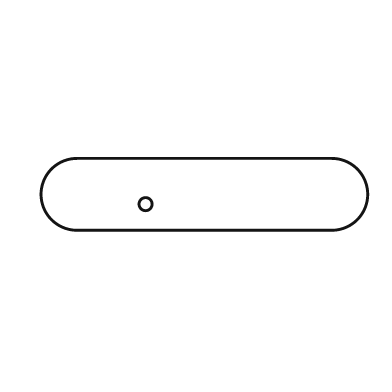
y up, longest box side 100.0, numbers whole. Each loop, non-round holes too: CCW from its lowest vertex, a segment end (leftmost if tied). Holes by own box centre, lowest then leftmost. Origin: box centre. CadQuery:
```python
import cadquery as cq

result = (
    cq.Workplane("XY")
    .moveTo(-39.0, -11.0)
    .lineTo(39.0, -11.0)
    .threePointArc((50.0, 0.0), (39.0, 11.0))
    .lineTo(-39.0, 11.0)
    .threePointArc((-50.0, 0.0), (-39.0, -11.0))
    .close()
    .moveTo(-18.0, -3.0)
    .circle(2.0)
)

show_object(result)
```